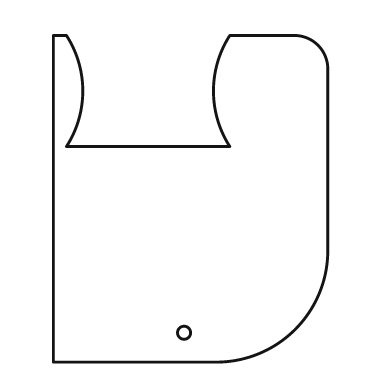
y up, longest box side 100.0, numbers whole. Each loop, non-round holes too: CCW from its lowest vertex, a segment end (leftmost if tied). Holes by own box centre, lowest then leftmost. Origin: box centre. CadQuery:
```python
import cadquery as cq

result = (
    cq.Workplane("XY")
    .moveTo(-42.0, -50.0)
    .lineTo(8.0, -50.0)
    .threePointArc((32.0, -40.0), (42.0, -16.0))
    .lineTo(42.0, 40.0)
    .threePointArc((39.0, 47.0), (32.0, 50.0))
    .lineTo(12.0, 50.0)
    .threePointArc((7.0, 33.0), (12.0, 16.0))
    .lineTo(-38.0, 16.0)
    .threePointArc((-33.0, 33.0), (-38.0, 50.0))
    .lineTo(-42.0, 50.0)
    .close()
    .moveTo(-2.0, -41.0)
    .circle(2.0)
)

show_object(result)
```